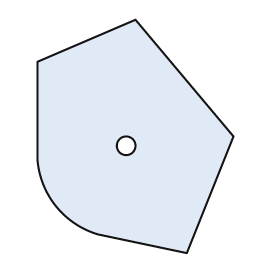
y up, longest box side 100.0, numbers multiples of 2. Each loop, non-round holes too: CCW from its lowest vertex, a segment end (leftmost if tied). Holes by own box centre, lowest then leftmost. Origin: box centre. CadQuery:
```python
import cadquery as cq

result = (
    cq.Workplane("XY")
    .moveTo(22.0, -50.0)
    .lineTo(42.0, 0.0)
    .lineTo(0.0, 50.0)
    .lineTo(-42.0, 32.0)
    .lineTo(-42.0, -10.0)
    .threePointArc((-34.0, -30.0), (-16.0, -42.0))
    .close()
    .moveTo(-4.0, -4.0)
    .circle(4.0)
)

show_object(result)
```